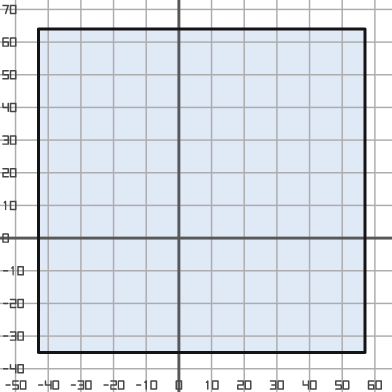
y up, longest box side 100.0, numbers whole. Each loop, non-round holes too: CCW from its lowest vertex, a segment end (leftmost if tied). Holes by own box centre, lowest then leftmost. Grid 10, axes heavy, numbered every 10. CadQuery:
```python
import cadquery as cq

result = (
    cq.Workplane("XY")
    .moveTo(-43.0, -35.0)
    .lineTo(57.0, -35.0)
    .lineTo(57.0, 64.0)
    .lineTo(-43.0, 64.0)
    .close()
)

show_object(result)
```